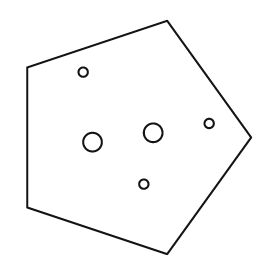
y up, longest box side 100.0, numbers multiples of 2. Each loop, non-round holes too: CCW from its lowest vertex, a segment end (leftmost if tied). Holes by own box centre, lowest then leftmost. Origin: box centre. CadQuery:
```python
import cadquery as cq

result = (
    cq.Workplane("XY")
    .moveTo(12.0, -50.0)
    .lineTo(48.0, 0.0)
    .lineTo(12.0, 50.0)
    .lineTo(-48.0, 30.0)
    .lineTo(-48.0, -30.0)
    .close()
    .moveTo(2.0, -20.0)
    .circle(2.0)
    .moveTo(-20.0, -2.0)
    .circle(4.0)
    .moveTo(6.0, 2.0)
    .circle(4.0)
    .moveTo(30.0, 6.0)
    .circle(2.0)
    .moveTo(-24.0, 28.0)
    .circle(2.0)
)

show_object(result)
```